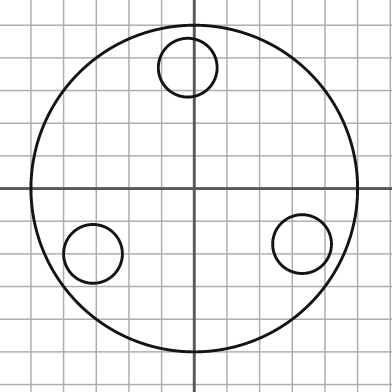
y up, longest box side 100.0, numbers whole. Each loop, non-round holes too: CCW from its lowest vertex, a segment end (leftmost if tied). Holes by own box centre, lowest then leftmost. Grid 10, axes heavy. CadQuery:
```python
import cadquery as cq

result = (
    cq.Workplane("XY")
    .moveTo(0.0, 0.0)
    .circle(50.0)
    .moveTo(-31.0, -20.0)
    .circle(9.0)
    .moveTo(33.0, -17.0)
    .circle(9.0)
    .moveTo(-2.0, 37.0)
    .circle(9.0)
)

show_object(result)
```